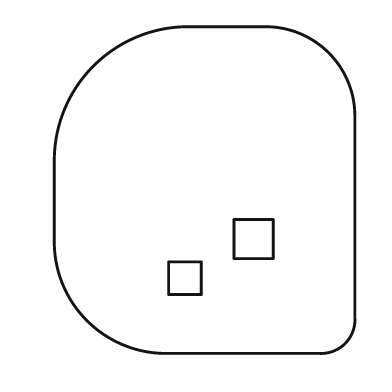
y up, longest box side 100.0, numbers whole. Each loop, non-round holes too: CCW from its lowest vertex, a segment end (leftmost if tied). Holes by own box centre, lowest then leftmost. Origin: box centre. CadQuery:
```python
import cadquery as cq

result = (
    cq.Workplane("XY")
    .moveTo(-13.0, -50.0)
    .lineTo(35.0, -50.0)
    .threePointArc((43.0, -47.0), (46.0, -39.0))
    .lineTo(46.0, 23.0)
    .threePointArc((38.0, 42.0), (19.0, 50.0))
    .lineTo(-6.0, 50.0)
    .threePointArc((-34.0, 38.0), (-46.0, 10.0))
    .lineTo(-46.0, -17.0)
    .threePointArc((-36.0, -40.0), (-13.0, -50.0))
    .close()
    .moveTo(-11.0, -32.0)
    .lineTo(-1.0, -32.0)
    .lineTo(-1.0, -22.0)
    .lineTo(-11.0, -22.0)
    .close()
    .moveTo(9.0, -21.0)
    .lineTo(21.0, -21.0)
    .lineTo(21.0, -9.0)
    .lineTo(9.0, -9.0)
    .close()
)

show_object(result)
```